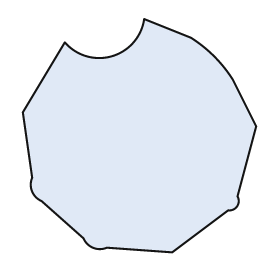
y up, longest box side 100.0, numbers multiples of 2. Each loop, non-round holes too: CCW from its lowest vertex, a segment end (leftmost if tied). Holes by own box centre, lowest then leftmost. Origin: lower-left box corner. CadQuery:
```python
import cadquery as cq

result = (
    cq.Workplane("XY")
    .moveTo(64.0, 0.0)
    .lineTo(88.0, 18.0)
    .threePointArc((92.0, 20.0), (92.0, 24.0))
    .lineTo(100.0, 54.0)
    .lineTo(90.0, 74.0)
    .threePointArc((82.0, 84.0), (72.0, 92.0))
    .lineTo(52.0, 100.0)
    .threePointArc((38.0, 84.0), (18.0, 90.0))
    .lineTo(0.0, 60.0)
    .lineTo(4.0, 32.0)
    .threePointArc((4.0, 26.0), (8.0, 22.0))
    .lineTo(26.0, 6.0)
    .threePointArc((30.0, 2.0), (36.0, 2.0))
    .close()
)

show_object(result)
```